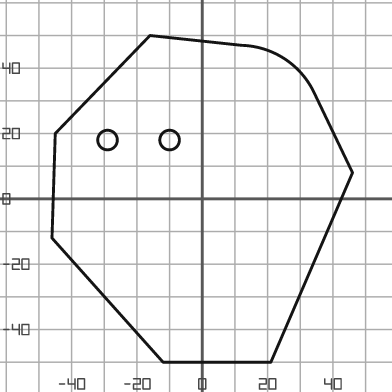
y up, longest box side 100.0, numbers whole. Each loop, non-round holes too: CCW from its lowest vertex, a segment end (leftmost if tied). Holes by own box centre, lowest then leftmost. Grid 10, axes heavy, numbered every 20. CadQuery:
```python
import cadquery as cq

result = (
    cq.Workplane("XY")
    .moveTo(-12.0, -50.0)
    .lineTo(21.0, -50.0)
    .lineTo(46.0, 8.0)
    .lineTo(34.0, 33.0)
    .threePointArc((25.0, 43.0), (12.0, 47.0))
    .lineTo(-16.0, 50.0)
    .lineTo(-45.0, 20.0)
    .lineTo(-46.0, -12.0)
    .close()
    .moveTo(-29.0, 18.0)
    .circle(3.0)
    .moveTo(-10.0, 18.0)
    .circle(3.0)
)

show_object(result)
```